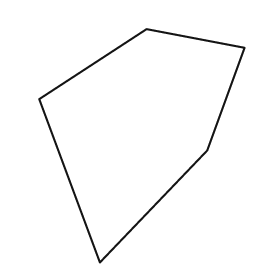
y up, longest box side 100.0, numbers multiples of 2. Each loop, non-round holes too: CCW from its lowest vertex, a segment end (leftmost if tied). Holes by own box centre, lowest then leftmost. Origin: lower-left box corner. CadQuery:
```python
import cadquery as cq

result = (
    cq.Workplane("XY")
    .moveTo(26.0, 0.0)
    .lineTo(72.0, 48.0)
    .lineTo(88.0, 92.0)
    .lineTo(46.0, 100.0)
    .lineTo(0.0, 70.0)
    .close()
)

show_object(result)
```